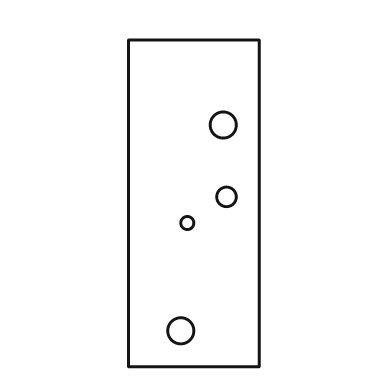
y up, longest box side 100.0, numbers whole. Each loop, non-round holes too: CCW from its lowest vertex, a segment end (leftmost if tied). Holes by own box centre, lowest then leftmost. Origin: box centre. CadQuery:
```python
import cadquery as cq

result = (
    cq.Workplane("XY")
    .moveTo(-20.0, -50.0)
    .lineTo(20.0, -50.0)
    .lineTo(20.0, 50.0)
    .lineTo(-20.0, 50.0)
    .close()
    .moveTo(-4.0, -39.0)
    .circle(4.0)
    .moveTo(-2.0, -6.0)
    .circle(2.0)
    .moveTo(10.0, 2.0)
    .circle(3.0)
    .moveTo(9.0, 24.0)
    .circle(4.0)
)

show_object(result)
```